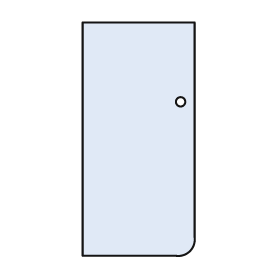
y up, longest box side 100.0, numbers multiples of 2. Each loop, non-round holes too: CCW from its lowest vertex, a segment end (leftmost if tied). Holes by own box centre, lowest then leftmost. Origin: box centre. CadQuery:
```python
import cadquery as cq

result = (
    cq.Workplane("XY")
    .moveTo(-24.0, -50.0)
    .lineTo(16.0, -50.0)
    .threePointArc((22.0, -48.0), (24.0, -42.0))
    .lineTo(24.0, 50.0)
    .lineTo(-24.0, 50.0)
    .close()
    .moveTo(18.0, 16.0)
    .circle(2.0)
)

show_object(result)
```